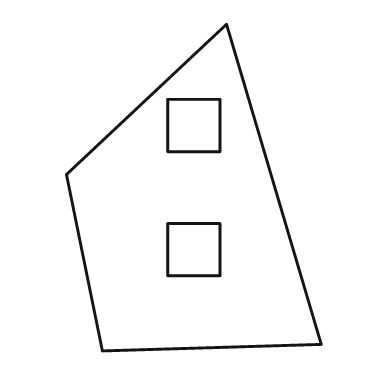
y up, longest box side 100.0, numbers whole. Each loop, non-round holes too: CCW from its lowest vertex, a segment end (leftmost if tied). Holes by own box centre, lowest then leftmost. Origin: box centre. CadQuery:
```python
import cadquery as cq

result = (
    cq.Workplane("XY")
    .moveTo(-28.0, -50.0)
    .lineTo(39.0, -48.0)
    .lineTo(10.0, 50.0)
    .lineTo(-39.0, 4.0)
    .close()
    .moveTo(-8.0, -27.0)
    .lineTo(8.0, -27.0)
    .lineTo(8.0, -11.0)
    .lineTo(-8.0, -11.0)
    .close()
    .moveTo(-8.0, 11.0)
    .lineTo(8.0, 11.0)
    .lineTo(8.0, 27.0)
    .lineTo(-8.0, 27.0)
    .close()
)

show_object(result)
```